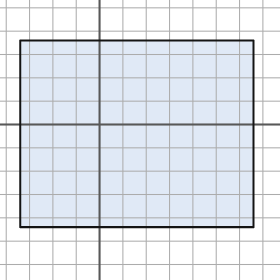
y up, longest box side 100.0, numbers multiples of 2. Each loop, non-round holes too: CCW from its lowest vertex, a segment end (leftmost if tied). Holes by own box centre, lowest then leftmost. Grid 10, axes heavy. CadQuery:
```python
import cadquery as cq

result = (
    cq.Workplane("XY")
    .moveTo(-34.0, -44.0)
    .lineTo(66.0, -44.0)
    .lineTo(66.0, 36.0)
    .lineTo(-34.0, 36.0)
    .close()
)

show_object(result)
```